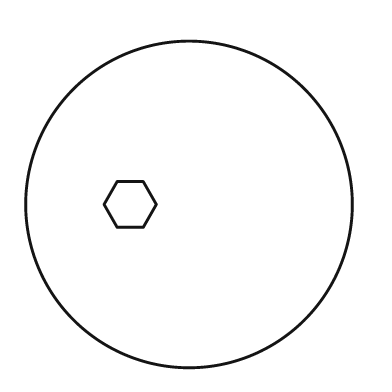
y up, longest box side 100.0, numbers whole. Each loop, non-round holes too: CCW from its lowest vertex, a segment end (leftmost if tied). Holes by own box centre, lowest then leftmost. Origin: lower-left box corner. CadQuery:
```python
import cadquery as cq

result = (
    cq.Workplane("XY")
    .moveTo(50.0, 50.0)
    .circle(50.0)
    .moveTo(28.0, 43.0)
    .lineTo(36.0, 43.0)
    .lineTo(40.0, 50.0)
    .lineTo(36.0, 57.0)
    .lineTo(28.0, 57.0)
    .lineTo(24.0, 50.0)
    .close()
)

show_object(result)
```